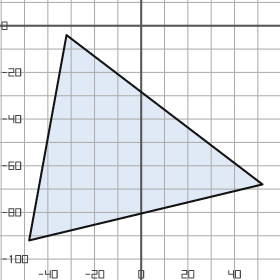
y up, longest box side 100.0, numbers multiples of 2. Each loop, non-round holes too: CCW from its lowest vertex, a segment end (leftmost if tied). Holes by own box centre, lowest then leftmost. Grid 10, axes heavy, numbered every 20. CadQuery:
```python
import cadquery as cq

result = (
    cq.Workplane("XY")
    .moveTo(-48.0, -92.0)
    .lineTo(52.0, -68.0)
    .lineTo(-32.0, -4.0)
    .close()
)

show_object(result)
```